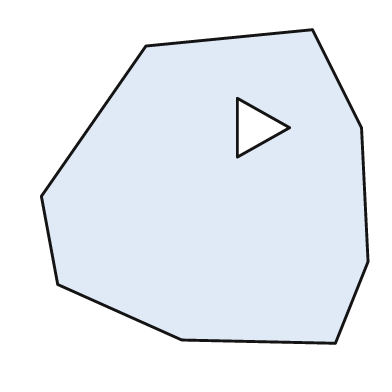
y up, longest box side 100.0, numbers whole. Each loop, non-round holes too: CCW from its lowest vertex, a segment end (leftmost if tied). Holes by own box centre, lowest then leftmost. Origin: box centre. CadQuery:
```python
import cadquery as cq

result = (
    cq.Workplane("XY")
    .moveTo(40.0, -48.0)
    .lineTo(50.0, -23.0)
    .lineTo(48.0, 18.0)
    .lineTo(33.0, 48.0)
    .lineTo(-18.0, 43.0)
    .lineTo(-50.0, -3.0)
    .lineTo(-45.0, -30.0)
    .lineTo(-7.0, -47.0)
    .close()
    .moveTo(10.0, 9.0)
    .lineTo(26.0, 18.0)
    .lineTo(10.0, 27.0)
    .close()
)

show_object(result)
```